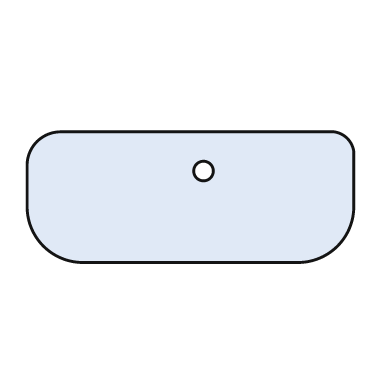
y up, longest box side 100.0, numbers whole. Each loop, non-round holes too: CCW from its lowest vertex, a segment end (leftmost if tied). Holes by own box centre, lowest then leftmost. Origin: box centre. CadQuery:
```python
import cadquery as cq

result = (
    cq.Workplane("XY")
    .moveTo(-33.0, -20.0)
    .lineTo(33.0, -20.0)
    .threePointArc((45.0, -15.0), (50.0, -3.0))
    .lineTo(50.0, 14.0)
    .threePointArc((48.0, 18.0), (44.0, 20.0))
    .lineTo(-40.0, 20.0)
    .threePointArc((-47.0, 17.0), (-50.0, 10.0))
    .lineTo(-50.0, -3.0)
    .threePointArc((-45.0, -15.0), (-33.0, -20.0))
    .close()
    .moveTo(4.0, 8.0)
    .circle(3.0)
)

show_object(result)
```